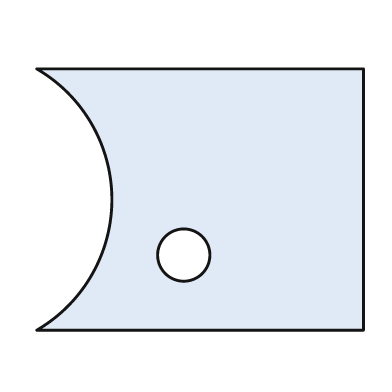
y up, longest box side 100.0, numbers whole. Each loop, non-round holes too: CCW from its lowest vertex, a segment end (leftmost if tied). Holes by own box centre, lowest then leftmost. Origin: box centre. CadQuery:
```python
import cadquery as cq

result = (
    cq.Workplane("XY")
    .moveTo(-50.0, -40.0)
    .lineTo(50.0, -40.0)
    .lineTo(50.0, 40.0)
    .lineTo(-50.0, 40.0)
    .threePointArc((-27.0, 0.0), (-50.0, -40.0))
    .close()
    .moveTo(-5.0, -17.0)
    .circle(8.0)
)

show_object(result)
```